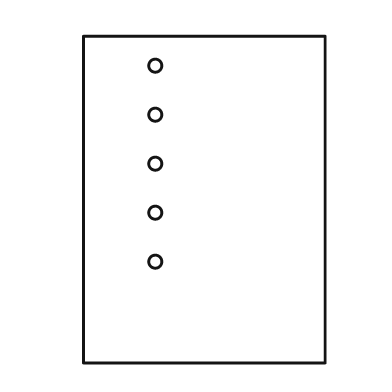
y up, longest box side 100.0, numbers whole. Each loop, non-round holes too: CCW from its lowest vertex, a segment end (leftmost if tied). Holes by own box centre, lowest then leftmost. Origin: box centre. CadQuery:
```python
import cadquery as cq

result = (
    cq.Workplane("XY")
    .moveTo(-37.0, -50.0)
    .lineTo(37.0, -50.0)
    .lineTo(37.0, 50.0)
    .lineTo(-37.0, 50.0)
    .close()
    .moveTo(-15.0, -19.0)
    .circle(2.0)
    .moveTo(-15.0, -4.0)
    .circle(2.0)
    .moveTo(-15.0, 11.0)
    .circle(2.0)
    .moveTo(-15.0, 26.0)
    .circle(2.0)
    .moveTo(-15.0, 41.0)
    .circle(2.0)
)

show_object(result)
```